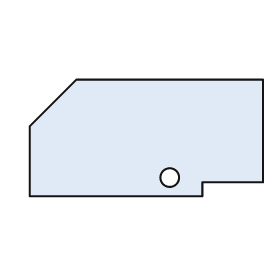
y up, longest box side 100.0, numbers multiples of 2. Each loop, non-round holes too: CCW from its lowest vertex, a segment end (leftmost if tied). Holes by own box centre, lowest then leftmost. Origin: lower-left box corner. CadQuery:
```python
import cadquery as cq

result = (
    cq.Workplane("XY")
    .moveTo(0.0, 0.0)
    .lineTo(74.0, 0.0)
    .lineTo(74.0, 6.0)
    .lineTo(100.0, 6.0)
    .lineTo(100.0, 50.0)
    .lineTo(20.0, 50.0)
    .lineTo(0.0, 30.0)
    .close()
    .moveTo(60.0, 8.0)
    .circle(4.0)
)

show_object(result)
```